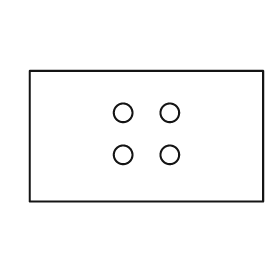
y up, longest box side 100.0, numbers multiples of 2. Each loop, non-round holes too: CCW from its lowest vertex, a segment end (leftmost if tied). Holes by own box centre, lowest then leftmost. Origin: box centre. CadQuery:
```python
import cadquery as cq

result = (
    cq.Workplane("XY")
    .moveTo(-50.0, -28.0)
    .lineTo(50.0, -28.0)
    .lineTo(50.0, 28.0)
    .lineTo(-50.0, 28.0)
    .close()
    .moveTo(-10.0, -8.0)
    .circle(4.0)
    .moveTo(10.0, -8.0)
    .circle(4.0)
    .moveTo(-10.0, 10.0)
    .circle(4.0)
    .moveTo(10.0, 10.0)
    .circle(4.0)
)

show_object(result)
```